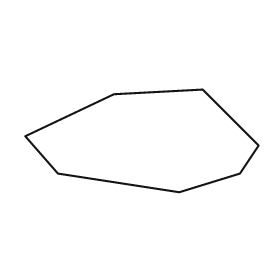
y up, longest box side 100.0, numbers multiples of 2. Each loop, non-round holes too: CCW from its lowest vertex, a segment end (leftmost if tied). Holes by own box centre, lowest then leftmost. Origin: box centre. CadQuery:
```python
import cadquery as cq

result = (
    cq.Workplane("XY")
    .moveTo(16.0, -22.0)
    .lineTo(42.0, -14.0)
    .lineTo(50.0, -2.0)
    .lineTo(26.0, 22.0)
    .lineTo(-12.0, 20.0)
    .lineTo(-50.0, 2.0)
    .lineTo(-36.0, -14.0)
    .close()
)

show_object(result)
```